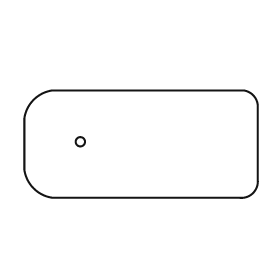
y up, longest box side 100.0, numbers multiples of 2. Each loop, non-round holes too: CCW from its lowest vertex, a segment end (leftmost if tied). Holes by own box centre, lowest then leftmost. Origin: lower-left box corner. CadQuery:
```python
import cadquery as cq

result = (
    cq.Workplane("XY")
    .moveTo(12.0, 0.0)
    .lineTo(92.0, 0.0)
    .threePointArc((98.0, 2.0), (100.0, 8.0))
    .lineTo(100.0, 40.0)
    .threePointArc((98.0, 44.0), (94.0, 46.0))
    .lineTo(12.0, 46.0)
    .threePointArc((4.0, 42.0), (0.0, 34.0))
    .lineTo(0.0, 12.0)
    .threePointArc((4.0, 4.0), (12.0, 0.0))
    .close()
    .moveTo(24.0, 24.0)
    .circle(2.0)
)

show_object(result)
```